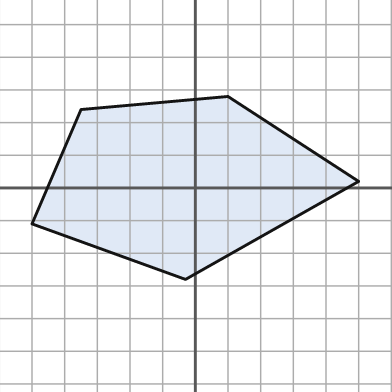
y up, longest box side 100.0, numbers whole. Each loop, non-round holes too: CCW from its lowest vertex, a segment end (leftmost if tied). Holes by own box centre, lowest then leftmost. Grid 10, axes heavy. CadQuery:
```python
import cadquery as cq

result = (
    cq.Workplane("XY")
    .moveTo(-3.0, -28.0)
    .lineTo(50.0, 2.0)
    .lineTo(10.0, 28.0)
    .lineTo(-35.0, 24.0)
    .lineTo(-50.0, -11.0)
    .close()
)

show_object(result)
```